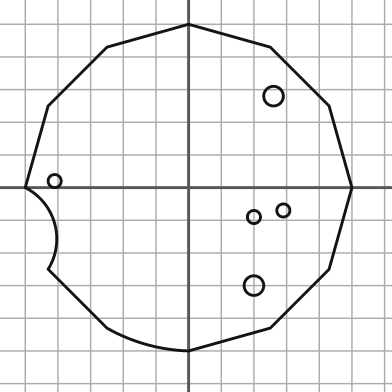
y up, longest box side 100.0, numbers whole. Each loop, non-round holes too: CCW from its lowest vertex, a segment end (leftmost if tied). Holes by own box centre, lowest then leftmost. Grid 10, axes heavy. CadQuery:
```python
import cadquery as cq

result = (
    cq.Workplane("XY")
    .moveTo(0.0, -50.0)
    .lineTo(25.0, -43.0)
    .lineTo(43.0, -25.0)
    .lineTo(50.0, 0.0)
    .lineTo(43.0, 25.0)
    .lineTo(25.0, 43.0)
    .lineTo(0.0, 50.0)
    .lineTo(-25.0, 43.0)
    .lineTo(-43.0, 25.0)
    .lineTo(-50.0, 0.0)
    .threePointArc((-41.0, -11.0), (-43.0, -25.0))
    .lineTo(-25.0, -43.0)
    .threePointArc((-13.0, -48.0), (0.0, -50.0))
    .close()
    .moveTo(20.0, -30.0)
    .circle(3.0)
    .moveTo(20.0, -9.0)
    .circle(2.0)
    .moveTo(29.0, -7.0)
    .circle(2.0)
    .moveTo(-41.0, 2.0)
    .circle(2.0)
    .moveTo(26.0, 28.0)
    .circle(3.0)
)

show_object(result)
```